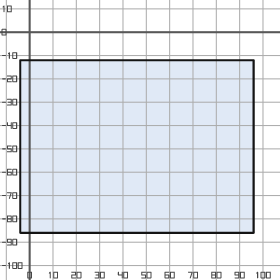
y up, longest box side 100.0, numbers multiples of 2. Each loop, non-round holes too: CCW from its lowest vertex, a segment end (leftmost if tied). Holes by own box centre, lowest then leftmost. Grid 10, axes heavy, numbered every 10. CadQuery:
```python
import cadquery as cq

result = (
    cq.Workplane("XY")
    .moveTo(-4.0, -86.0)
    .lineTo(96.0, -86.0)
    .lineTo(96.0, -12.0)
    .lineTo(-4.0, -12.0)
    .close()
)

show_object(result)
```